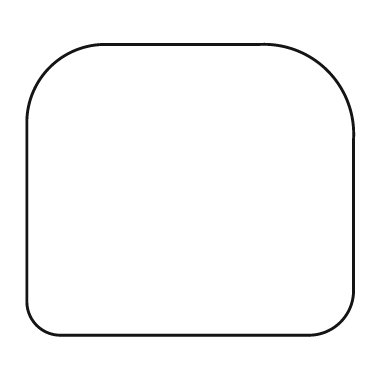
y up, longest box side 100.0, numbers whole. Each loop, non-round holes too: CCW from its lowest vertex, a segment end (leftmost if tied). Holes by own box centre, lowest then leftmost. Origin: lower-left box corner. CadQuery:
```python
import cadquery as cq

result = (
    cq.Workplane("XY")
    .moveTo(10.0, 0.0)
    .lineTo(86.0, 0.0)
    .threePointArc((96.0, 4.0), (100.0, 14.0))
    .lineTo(100.0, 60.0)
    .threePointArc((92.0, 81.0), (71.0, 89.0))
    .lineTo(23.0, 89.0)
    .threePointArc((7.0, 82.0), (0.0, 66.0))
    .lineTo(0.0, 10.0)
    .threePointArc((3.0, 3.0), (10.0, 0.0))
    .close()
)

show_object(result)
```